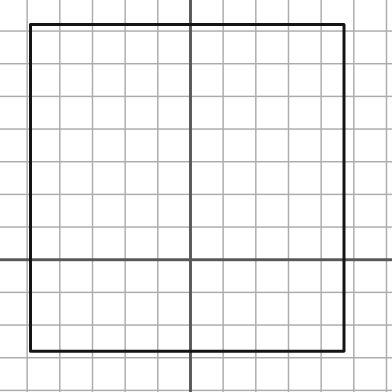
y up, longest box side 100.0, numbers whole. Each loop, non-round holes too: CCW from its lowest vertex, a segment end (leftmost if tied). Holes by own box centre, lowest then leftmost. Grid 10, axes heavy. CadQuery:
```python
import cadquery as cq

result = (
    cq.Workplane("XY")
    .moveTo(-49.0, -28.0)
    .lineTo(47.0, -28.0)
    .lineTo(47.0, 72.0)
    .lineTo(-49.0, 72.0)
    .close()
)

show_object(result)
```